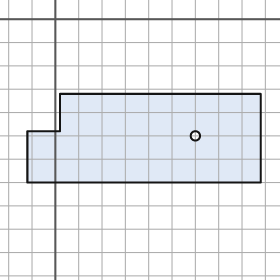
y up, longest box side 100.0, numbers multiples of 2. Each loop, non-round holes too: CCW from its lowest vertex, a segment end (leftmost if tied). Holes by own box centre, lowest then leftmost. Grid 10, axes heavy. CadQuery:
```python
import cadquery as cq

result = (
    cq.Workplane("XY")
    .moveTo(-12.0, -70.0)
    .lineTo(88.0, -70.0)
    .lineTo(88.0, -32.0)
    .lineTo(2.0, -32.0)
    .lineTo(2.0, -48.0)
    .lineTo(-12.0, -48.0)
    .close()
    .moveTo(60.0, -50.0)
    .circle(2.0)
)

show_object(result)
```